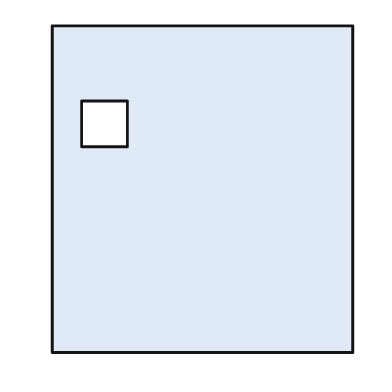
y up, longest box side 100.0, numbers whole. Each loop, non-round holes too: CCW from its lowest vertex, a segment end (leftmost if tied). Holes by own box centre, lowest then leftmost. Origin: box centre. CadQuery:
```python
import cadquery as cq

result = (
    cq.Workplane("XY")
    .moveTo(-46.0, -50.0)
    .lineTo(46.0, -50.0)
    .lineTo(46.0, 50.0)
    .lineTo(-46.0, 50.0)
    .close()
    .moveTo(-37.0, 13.0)
    .lineTo(-23.0, 13.0)
    .lineTo(-23.0, 27.0)
    .lineTo(-37.0, 27.0)
    .close()
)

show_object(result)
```